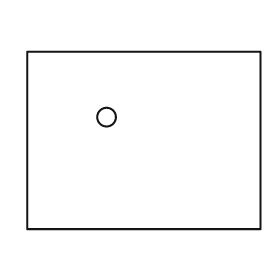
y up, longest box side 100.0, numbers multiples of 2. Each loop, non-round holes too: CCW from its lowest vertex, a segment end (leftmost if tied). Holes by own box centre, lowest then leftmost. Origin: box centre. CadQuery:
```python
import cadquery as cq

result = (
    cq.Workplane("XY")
    .moveTo(-50.0, -38.0)
    .lineTo(50.0, -38.0)
    .lineTo(50.0, 38.0)
    .lineTo(-50.0, 38.0)
    .close()
    .moveTo(-16.0, 10.0)
    .circle(4.0)
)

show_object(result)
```